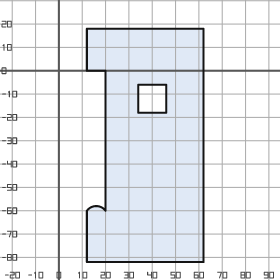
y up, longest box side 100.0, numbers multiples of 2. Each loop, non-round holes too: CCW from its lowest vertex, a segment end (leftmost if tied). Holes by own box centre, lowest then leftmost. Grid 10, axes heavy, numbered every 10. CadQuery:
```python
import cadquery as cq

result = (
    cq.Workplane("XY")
    .moveTo(12.0, -82.0)
    .lineTo(62.0, -82.0)
    .lineTo(62.0, 18.0)
    .lineTo(12.0, 18.0)
    .lineTo(12.0, 0.0)
    .lineTo(20.0, 0.0)
    .lineTo(20.0, -60.0)
    .threePointArc((16.0, -58.0), (12.0, -60.0))
    .close()
    .moveTo(34.0, -18.0)
    .lineTo(46.0, -18.0)
    .lineTo(46.0, -6.0)
    .lineTo(34.0, -6.0)
    .close()
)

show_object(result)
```